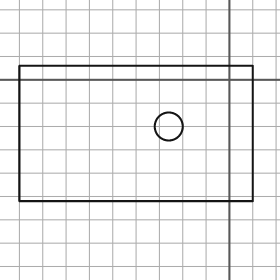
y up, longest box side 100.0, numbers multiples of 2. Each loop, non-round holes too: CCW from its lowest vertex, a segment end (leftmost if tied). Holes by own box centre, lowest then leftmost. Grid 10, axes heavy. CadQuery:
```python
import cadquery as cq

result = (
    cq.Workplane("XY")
    .moveTo(-90.0, -52.0)
    .lineTo(10.0, -52.0)
    .lineTo(10.0, 6.0)
    .lineTo(-90.0, 6.0)
    .close()
    .moveTo(-26.0, -20.0)
    .circle(6.0)
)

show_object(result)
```